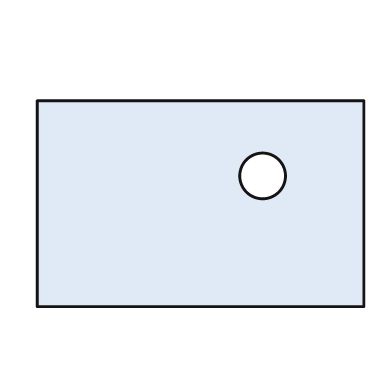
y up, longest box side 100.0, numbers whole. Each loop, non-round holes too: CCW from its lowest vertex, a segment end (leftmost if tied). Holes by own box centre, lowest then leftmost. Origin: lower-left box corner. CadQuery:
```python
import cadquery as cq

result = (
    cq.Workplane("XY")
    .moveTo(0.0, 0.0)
    .lineTo(100.0, 0.0)
    .lineTo(100.0, 63.0)
    .lineTo(0.0, 63.0)
    .close()
    .moveTo(69.0, 40.0)
    .circle(7.0)
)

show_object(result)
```